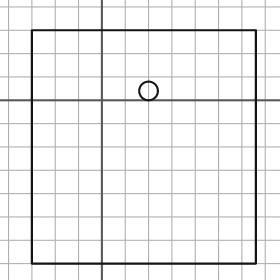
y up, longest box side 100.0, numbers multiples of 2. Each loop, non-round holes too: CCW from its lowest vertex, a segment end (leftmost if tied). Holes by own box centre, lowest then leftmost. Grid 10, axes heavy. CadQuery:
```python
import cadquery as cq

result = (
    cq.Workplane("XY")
    .moveTo(-30.0, -70.0)
    .lineTo(66.0, -70.0)
    .lineTo(66.0, 30.0)
    .lineTo(-30.0, 30.0)
    .close()
    .moveTo(20.0, 4.0)
    .circle(4.0)
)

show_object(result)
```